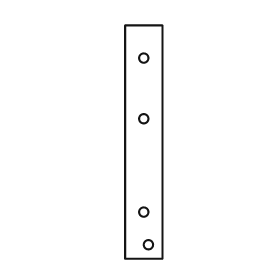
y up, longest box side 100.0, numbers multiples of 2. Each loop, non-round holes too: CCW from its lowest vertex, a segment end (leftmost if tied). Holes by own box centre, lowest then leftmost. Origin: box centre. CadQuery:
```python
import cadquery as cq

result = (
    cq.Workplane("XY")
    .moveTo(-8.0, -50.0)
    .lineTo(8.0, -50.0)
    .lineTo(8.0, 50.0)
    .lineTo(-8.0, 50.0)
    .close()
    .moveTo(2.0, -44.0)
    .circle(2.0)
    .moveTo(0.0, -30.0)
    .circle(2.0)
    .moveTo(0.0, 10.0)
    .circle(2.0)
    .moveTo(0.0, 36.0)
    .circle(2.0)
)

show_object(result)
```